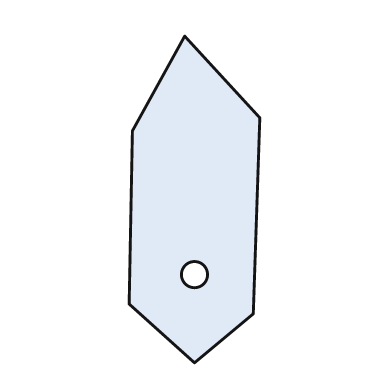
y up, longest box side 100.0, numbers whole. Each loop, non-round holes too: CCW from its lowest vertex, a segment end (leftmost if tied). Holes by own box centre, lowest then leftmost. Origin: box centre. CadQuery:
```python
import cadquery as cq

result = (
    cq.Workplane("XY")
    .moveTo(0.0, -50.0)
    .lineTo(18.0, -35.0)
    .lineTo(20.0, 25.0)
    .lineTo(-3.0, 50.0)
    .lineTo(-19.0, 21.0)
    .lineTo(-20.0, -32.0)
    .close()
    .moveTo(0.0, -23.0)
    .circle(4.0)
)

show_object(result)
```